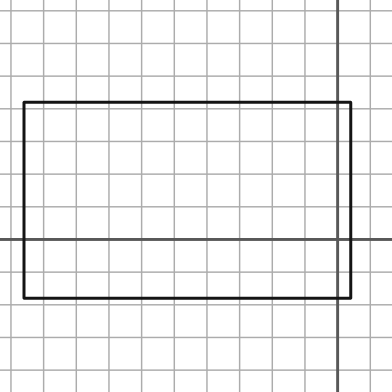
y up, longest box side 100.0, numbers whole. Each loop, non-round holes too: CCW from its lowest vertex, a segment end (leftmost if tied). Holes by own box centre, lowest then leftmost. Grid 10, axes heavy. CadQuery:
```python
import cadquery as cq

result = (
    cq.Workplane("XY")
    .moveTo(-96.0, -18.0)
    .lineTo(4.0, -18.0)
    .lineTo(4.0, 42.0)
    .lineTo(-96.0, 42.0)
    .close()
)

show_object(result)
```